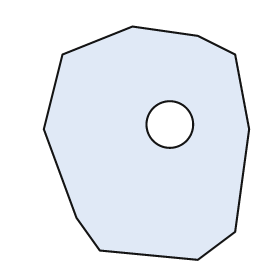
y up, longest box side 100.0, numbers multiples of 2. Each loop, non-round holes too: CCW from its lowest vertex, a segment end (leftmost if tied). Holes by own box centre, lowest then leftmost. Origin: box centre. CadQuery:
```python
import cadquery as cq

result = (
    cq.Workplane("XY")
    .moveTo(22.0, -50.0)
    .lineTo(38.0, -38.0)
    .lineTo(44.0, 6.0)
    .lineTo(38.0, 38.0)
    .lineTo(22.0, 46.0)
    .lineTo(-6.0, 50.0)
    .lineTo(-36.0, 38.0)
    .lineTo(-44.0, 6.0)
    .lineTo(-30.0, -32.0)
    .lineTo(-20.0, -46.0)
    .close()
    .moveTo(10.0, 8.0)
    .circle(10.0)
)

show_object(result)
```